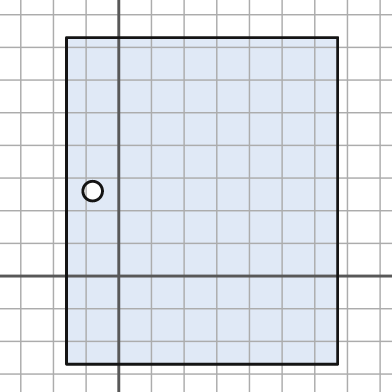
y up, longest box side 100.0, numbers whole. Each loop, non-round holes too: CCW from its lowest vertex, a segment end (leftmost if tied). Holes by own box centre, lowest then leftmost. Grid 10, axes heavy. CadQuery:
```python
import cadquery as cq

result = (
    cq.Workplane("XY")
    .moveTo(-16.0, -27.0)
    .lineTo(67.0, -27.0)
    .lineTo(67.0, 73.0)
    .lineTo(-16.0, 73.0)
    .close()
    .moveTo(-8.0, 26.0)
    .circle(3.0)
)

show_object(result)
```